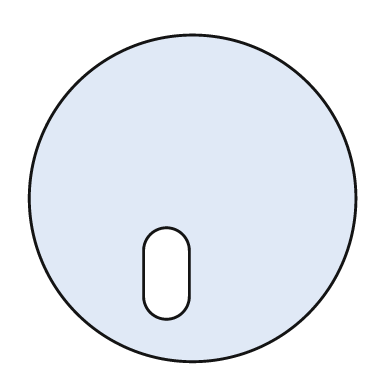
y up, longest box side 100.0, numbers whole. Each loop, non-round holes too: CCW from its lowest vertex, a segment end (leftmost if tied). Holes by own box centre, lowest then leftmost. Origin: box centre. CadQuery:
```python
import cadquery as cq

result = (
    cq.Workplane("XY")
    .moveTo(0.0, 0.0)
    .circle(50.0)
    .moveTo(-15.0, -30.0)
    .threePointArc((-8.0, -37.0), (-1.0, -30.0))
    .lineTo(-1.0, -16.0)
    .threePointArc((-8.0, -9.0), (-15.0, -16.0))
    .close()
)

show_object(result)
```